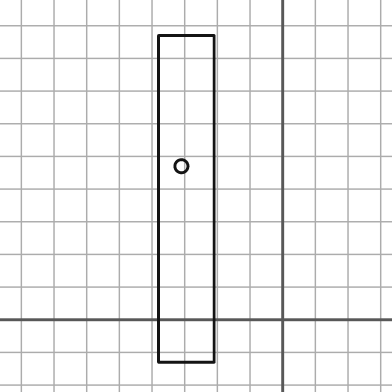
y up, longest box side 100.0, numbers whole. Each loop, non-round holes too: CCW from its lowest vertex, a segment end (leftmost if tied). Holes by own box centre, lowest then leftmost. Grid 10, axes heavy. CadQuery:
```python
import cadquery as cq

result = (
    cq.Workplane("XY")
    .moveTo(-38.0, -13.0)
    .lineTo(-21.0, -13.0)
    .lineTo(-21.0, 87.0)
    .lineTo(-38.0, 87.0)
    .close()
    .moveTo(-31.0, 47.0)
    .circle(2.0)
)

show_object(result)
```